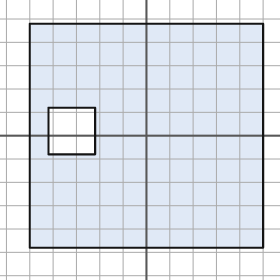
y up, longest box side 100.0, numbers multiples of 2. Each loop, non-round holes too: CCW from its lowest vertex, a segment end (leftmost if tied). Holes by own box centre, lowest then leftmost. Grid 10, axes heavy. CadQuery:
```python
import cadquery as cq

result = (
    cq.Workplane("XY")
    .moveTo(-50.0, -48.0)
    .lineTo(50.0, -48.0)
    .lineTo(50.0, 48.0)
    .lineTo(-50.0, 48.0)
    .close()
    .moveTo(-42.0, -8.0)
    .lineTo(-22.0, -8.0)
    .lineTo(-22.0, 12.0)
    .lineTo(-42.0, 12.0)
    .close()
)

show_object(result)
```